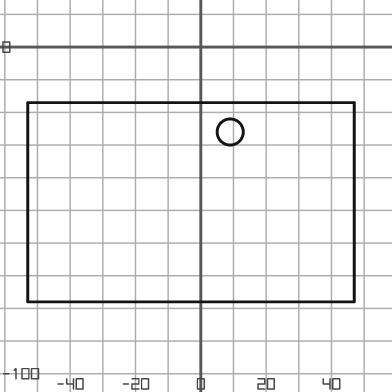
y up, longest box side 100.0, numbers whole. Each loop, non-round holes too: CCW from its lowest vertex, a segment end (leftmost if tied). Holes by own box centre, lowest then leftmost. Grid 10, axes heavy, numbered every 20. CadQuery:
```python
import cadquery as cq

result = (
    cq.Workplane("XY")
    .moveTo(-53.0, -78.0)
    .lineTo(47.0, -78.0)
    .lineTo(47.0, -17.0)
    .lineTo(-53.0, -17.0)
    .close()
    .moveTo(9.0, -26.0)
    .circle(4.0)
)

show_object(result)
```